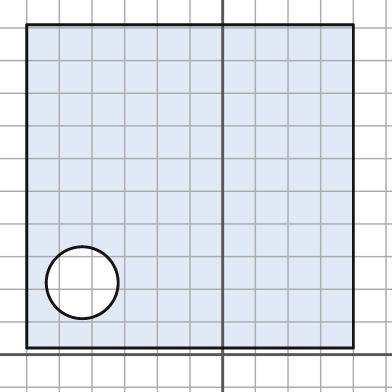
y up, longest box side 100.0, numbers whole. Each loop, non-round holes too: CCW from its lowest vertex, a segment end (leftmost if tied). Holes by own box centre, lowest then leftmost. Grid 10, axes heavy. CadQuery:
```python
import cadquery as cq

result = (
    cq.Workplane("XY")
    .moveTo(-60.0, 2.0)
    .lineTo(40.0, 2.0)
    .lineTo(40.0, 101.0)
    .lineTo(-60.0, 101.0)
    .close()
    .moveTo(-43.0, 22.0)
    .circle(11.0)
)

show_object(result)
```